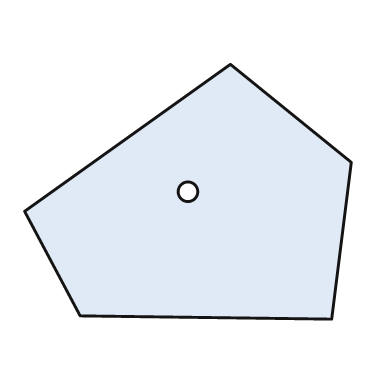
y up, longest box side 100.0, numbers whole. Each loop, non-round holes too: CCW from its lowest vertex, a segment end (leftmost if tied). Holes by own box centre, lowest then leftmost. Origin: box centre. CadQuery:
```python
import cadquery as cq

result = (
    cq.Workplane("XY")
    .moveTo(44.0, -39.0)
    .lineTo(50.0, 9.0)
    .lineTo(13.0, 39.0)
    .lineTo(-50.0, -6.0)
    .lineTo(-33.0, -38.0)
    .close()
    .moveTo(0.0, 0.0)
    .circle(3.0)
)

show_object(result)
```